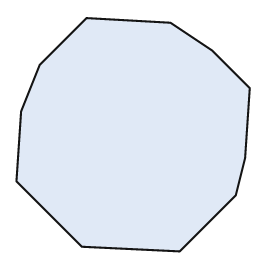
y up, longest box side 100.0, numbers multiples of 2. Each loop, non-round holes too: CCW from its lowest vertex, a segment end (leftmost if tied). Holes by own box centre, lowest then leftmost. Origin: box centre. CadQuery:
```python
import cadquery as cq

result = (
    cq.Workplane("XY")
    .moveTo(20.0, -50.0)
    .lineTo(44.0, -26.0)
    .lineTo(48.0, -10.0)
    .lineTo(50.0, 20.0)
    .lineTo(34.0, 36.0)
    .lineTo(16.0, 48.0)
    .lineTo(-20.0, 50.0)
    .lineTo(-40.0, 30.0)
    .lineTo(-48.0, 10.0)
    .lineTo(-50.0, -20.0)
    .lineTo(-22.0, -48.0)
    .close()
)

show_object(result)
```